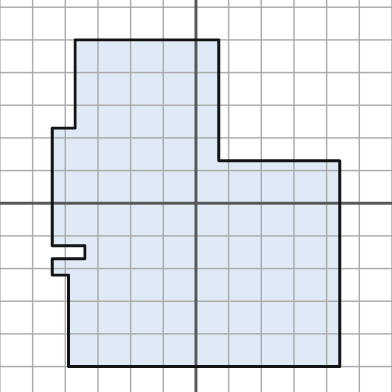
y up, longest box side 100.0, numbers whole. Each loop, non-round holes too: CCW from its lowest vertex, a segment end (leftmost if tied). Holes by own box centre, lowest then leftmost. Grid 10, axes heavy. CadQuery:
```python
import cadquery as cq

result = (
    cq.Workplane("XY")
    .moveTo(-39.0, -50.0)
    .lineTo(44.0, -50.0)
    .lineTo(44.0, 13.0)
    .lineTo(7.0, 13.0)
    .lineTo(7.0, 50.0)
    .lineTo(-37.0, 50.0)
    .lineTo(-37.0, 23.0)
    .lineTo(-44.0, 23.0)
    .lineTo(-44.0, -13.0)
    .lineTo(-34.0, -13.0)
    .lineTo(-34.0, -17.0)
    .lineTo(-44.0, -17.0)
    .lineTo(-44.0, -22.0)
    .lineTo(-39.0, -22.0)
    .close()
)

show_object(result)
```